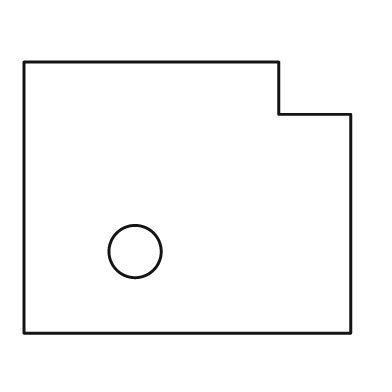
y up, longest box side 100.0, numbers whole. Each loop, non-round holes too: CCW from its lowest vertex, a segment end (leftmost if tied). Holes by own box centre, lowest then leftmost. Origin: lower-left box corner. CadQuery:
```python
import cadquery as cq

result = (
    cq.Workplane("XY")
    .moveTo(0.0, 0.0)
    .lineTo(100.0, 0.0)
    .lineTo(100.0, 67.0)
    .lineTo(78.0, 67.0)
    .lineTo(78.0, 83.0)
    .lineTo(0.0, 83.0)
    .close()
    .moveTo(34.0, 25.0)
    .circle(8.0)
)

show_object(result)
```